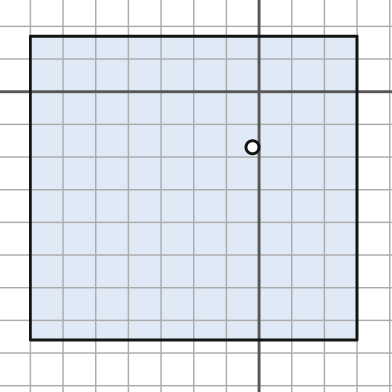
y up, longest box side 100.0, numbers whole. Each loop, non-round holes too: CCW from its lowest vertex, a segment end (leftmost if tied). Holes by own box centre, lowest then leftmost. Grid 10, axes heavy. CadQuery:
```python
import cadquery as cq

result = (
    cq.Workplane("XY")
    .moveTo(-70.0, -76.0)
    .lineTo(30.0, -76.0)
    .lineTo(30.0, 17.0)
    .lineTo(-70.0, 17.0)
    .close()
    .moveTo(-2.0, -17.0)
    .circle(2.0)
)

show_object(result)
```